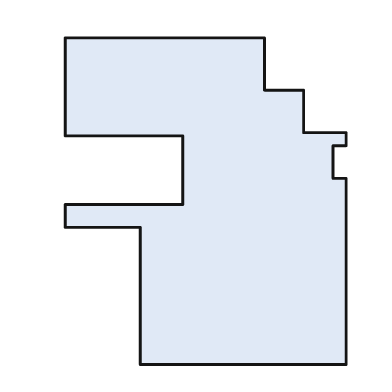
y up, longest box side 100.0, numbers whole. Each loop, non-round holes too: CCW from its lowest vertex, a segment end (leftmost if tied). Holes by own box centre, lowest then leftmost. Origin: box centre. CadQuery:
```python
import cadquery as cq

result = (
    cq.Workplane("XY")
    .moveTo(-20.0, -50.0)
    .lineTo(43.0, -50.0)
    .lineTo(43.0, 7.0)
    .lineTo(39.0, 7.0)
    .lineTo(39.0, 17.0)
    .lineTo(43.0, 17.0)
    .lineTo(43.0, 21.0)
    .lineTo(30.0, 21.0)
    .lineTo(30.0, 34.0)
    .lineTo(18.0, 34.0)
    .lineTo(18.0, 50.0)
    .lineTo(-43.0, 50.0)
    .lineTo(-43.0, 20.0)
    .lineTo(-7.0, 20.0)
    .lineTo(-7.0, -1.0)
    .lineTo(-43.0, -1.0)
    .lineTo(-43.0, -8.0)
    .lineTo(-20.0, -8.0)
    .close()
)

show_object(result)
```